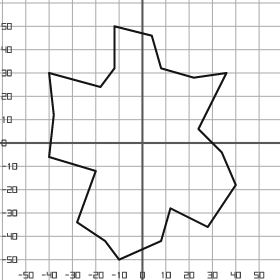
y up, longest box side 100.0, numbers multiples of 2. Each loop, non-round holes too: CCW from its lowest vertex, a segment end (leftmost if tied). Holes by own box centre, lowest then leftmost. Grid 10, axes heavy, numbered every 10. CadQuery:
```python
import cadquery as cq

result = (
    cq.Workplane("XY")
    .moveTo(-10.0, -50.0)
    .lineTo(8.0, -42.0)
    .lineTo(12.0, -28.0)
    .lineTo(28.0, -36.0)
    .lineTo(40.0, -18.0)
    .lineTo(34.0, -4.0)
    .lineTo(24.0, 6.0)
    .lineTo(36.0, 30.0)
    .lineTo(22.0, 28.0)
    .lineTo(8.0, 32.0)
    .lineTo(4.0, 46.0)
    .lineTo(-12.0, 50.0)
    .lineTo(-12.0, 32.0)
    .lineTo(-18.0, 24.0)
    .lineTo(-40.0, 30.0)
    .lineTo(-38.0, 12.0)
    .lineTo(-40.0, -6.0)
    .lineTo(-20.0, -12.0)
    .lineTo(-28.0, -34.0)
    .lineTo(-16.0, -42.0)
    .close()
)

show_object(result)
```